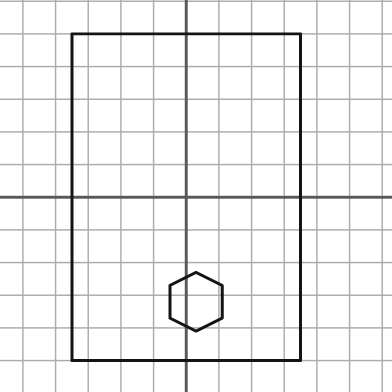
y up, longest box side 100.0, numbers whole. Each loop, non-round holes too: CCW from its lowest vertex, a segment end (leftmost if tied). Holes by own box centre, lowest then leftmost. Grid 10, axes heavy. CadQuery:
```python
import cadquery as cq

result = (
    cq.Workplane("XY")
    .moveTo(-35.0, -50.0)
    .lineTo(35.0, -50.0)
    .lineTo(35.0, 50.0)
    .lineTo(-35.0, 50.0)
    .close()
    .moveTo(3.0, -41.0)
    .lineTo(11.0, -37.0)
    .lineTo(11.0, -27.0)
    .lineTo(3.0, -23.0)
    .lineTo(-5.0, -27.0)
    .lineTo(-5.0, -37.0)
    .close()
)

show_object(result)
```